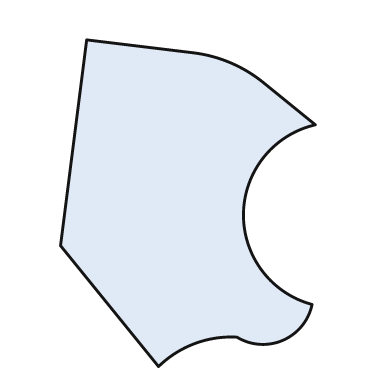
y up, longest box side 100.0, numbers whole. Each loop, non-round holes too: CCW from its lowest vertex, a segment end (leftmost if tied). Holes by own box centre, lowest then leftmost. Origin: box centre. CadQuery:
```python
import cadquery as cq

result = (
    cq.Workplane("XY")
    .moveTo(-9.0, -50.0)
    .threePointArc((2.0, -43.0), (15.0, -41.0))
    .threePointArc((29.0, -42.0), (38.0, -31.0))
    .threePointArc((17.0, -3.0), (39.0, 24.0))
    .lineTo(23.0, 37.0)
    .threePointArc((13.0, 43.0), (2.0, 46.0))
    .lineTo(-31.0, 50.0)
    .lineTo(-39.0, -13.0)
    .close()
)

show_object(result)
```